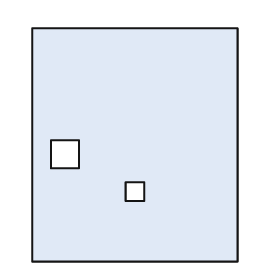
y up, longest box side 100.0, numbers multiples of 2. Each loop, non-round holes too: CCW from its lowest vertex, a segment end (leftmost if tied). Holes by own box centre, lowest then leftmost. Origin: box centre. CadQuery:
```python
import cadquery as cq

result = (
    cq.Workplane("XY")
    .moveTo(-44.0, -50.0)
    .lineTo(44.0, -50.0)
    .lineTo(44.0, 50.0)
    .lineTo(-44.0, 50.0)
    .close()
    .moveTo(-4.0, -24.0)
    .lineTo(4.0, -24.0)
    .lineTo(4.0, -16.0)
    .lineTo(-4.0, -16.0)
    .close()
    .moveTo(-36.0, -10.0)
    .lineTo(-24.0, -10.0)
    .lineTo(-24.0, 2.0)
    .lineTo(-36.0, 2.0)
    .close()
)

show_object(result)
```